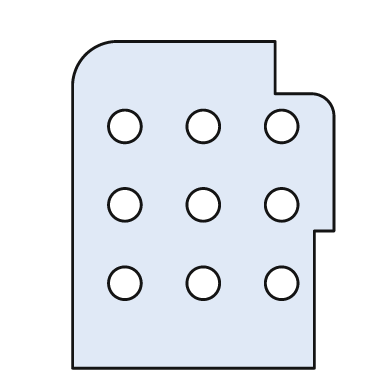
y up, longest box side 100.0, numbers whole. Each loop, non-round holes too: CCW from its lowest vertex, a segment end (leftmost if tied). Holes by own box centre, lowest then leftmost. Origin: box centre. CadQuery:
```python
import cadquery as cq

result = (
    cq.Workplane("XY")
    .moveTo(-40.0, -50.0)
    .lineTo(34.0, -50.0)
    .lineTo(34.0, -8.0)
    .lineTo(40.0, -8.0)
    .lineTo(40.0, 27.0)
    .threePointArc((38.0, 32.0), (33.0, 34.0))
    .lineTo(22.0, 34.0)
    .lineTo(22.0, 50.0)
    .lineTo(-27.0, 50.0)
    .threePointArc((-36.0, 46.0), (-40.0, 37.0))
    .close()
    .moveTo(-24.0, -24.0)
    .circle(5.0)
    .moveTo(0.0, -24.0)
    .circle(5.0)
    .moveTo(24.0, -24.0)
    .circle(5.0)
    .moveTo(-24.0, 0.0)
    .circle(5.0)
    .moveTo(0.0, 0.0)
    .circle(5.0)
    .moveTo(24.0, 0.0)
    .circle(5.0)
    .moveTo(-24.0, 24.0)
    .circle(5.0)
    .moveTo(0.0, 24.0)
    .circle(5.0)
    .moveTo(24.0, 24.0)
    .circle(5.0)
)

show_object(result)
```